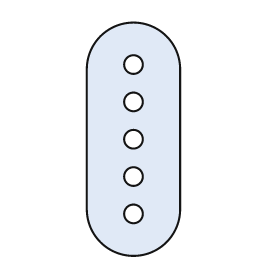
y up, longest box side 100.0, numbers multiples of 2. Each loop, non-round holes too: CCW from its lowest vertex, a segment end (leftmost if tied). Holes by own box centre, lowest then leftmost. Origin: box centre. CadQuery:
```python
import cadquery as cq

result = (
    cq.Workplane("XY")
    .moveTo(-20.0, -30.0)
    .threePointArc((0.0, -50.0), (20.0, -30.0))
    .lineTo(20.0, 30.0)
    .threePointArc((0.0, 50.0), (-20.0, 30.0))
    .close()
    .moveTo(0.0, -32.0)
    .circle(4.0)
    .moveTo(0.0, -16.0)
    .circle(4.0)
    .moveTo(0.0, 0.0)
    .circle(4.0)
    .moveTo(0.0, 16.0)
    .circle(4.0)
    .moveTo(0.0, 32.0)
    .circle(4.0)
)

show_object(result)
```